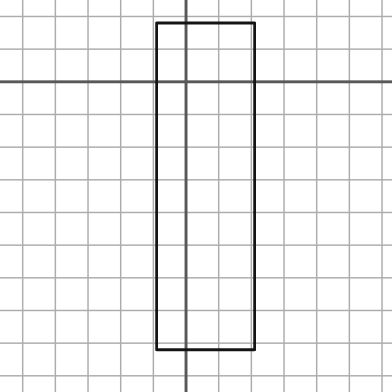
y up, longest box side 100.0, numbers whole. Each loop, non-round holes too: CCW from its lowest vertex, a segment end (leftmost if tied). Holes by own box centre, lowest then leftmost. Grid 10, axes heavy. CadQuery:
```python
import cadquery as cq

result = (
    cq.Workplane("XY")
    .moveTo(-9.0, -82.0)
    .lineTo(21.0, -82.0)
    .lineTo(21.0, 18.0)
    .lineTo(-9.0, 18.0)
    .close()
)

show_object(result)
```